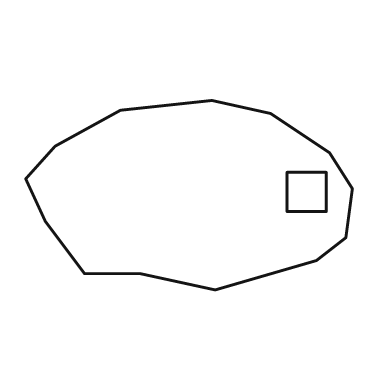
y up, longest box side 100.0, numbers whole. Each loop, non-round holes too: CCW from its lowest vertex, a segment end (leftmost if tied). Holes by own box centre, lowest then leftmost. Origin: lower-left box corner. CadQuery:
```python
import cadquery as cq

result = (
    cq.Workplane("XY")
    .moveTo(58.0, 0.0)
    .lineTo(89.0, 9.0)
    .lineTo(98.0, 16.0)
    .lineTo(100.0, 31.0)
    .lineTo(93.0, 42.0)
    .lineTo(75.0, 54.0)
    .lineTo(57.0, 58.0)
    .lineTo(29.0, 55.0)
    .lineTo(9.0, 44.0)
    .lineTo(0.0, 34.0)
    .lineTo(6.0, 21.0)
    .lineTo(18.0, 5.0)
    .lineTo(35.0, 5.0)
    .close()
    .moveTo(80.0, 24.0)
    .lineTo(92.0, 24.0)
    .lineTo(92.0, 36.0)
    .lineTo(80.0, 36.0)
    .close()
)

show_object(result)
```